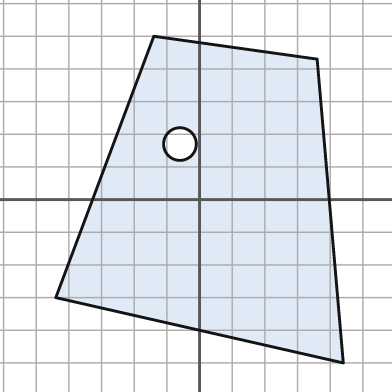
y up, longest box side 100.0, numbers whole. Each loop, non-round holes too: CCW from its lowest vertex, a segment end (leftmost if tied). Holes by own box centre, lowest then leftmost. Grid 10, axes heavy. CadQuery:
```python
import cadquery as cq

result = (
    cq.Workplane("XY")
    .moveTo(44.0, -50.0)
    .lineTo(36.0, 43.0)
    .lineTo(-14.0, 50.0)
    .lineTo(-44.0, -30.0)
    .close()
    .moveTo(-6.0, 17.0)
    .circle(5.0)
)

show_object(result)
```